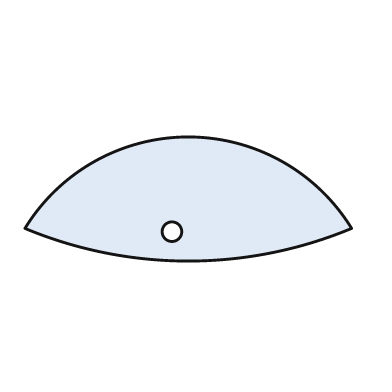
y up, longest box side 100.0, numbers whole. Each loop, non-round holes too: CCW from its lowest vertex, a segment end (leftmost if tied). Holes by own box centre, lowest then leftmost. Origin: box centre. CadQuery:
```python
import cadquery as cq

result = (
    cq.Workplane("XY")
    .moveTo(-50.0, -9.0)
    .threePointArc((0.0, -19.0), (50.0, -9.0))
    .threePointArc((0.0, 19.0), (-50.0, -9.0))
    .close()
    .moveTo(-5.0, -10.0)
    .circle(3.0)
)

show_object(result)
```